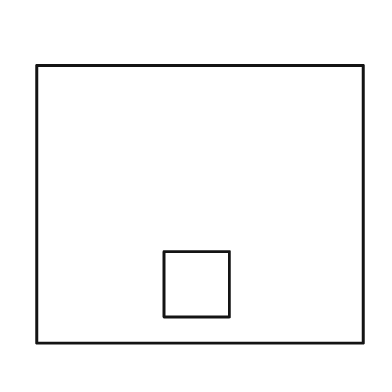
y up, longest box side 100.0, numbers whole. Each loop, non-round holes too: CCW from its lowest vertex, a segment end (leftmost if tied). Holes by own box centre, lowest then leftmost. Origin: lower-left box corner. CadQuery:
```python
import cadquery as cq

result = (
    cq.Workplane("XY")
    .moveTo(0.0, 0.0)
    .lineTo(100.0, 0.0)
    .lineTo(100.0, 85.0)
    .lineTo(0.0, 85.0)
    .close()
    .moveTo(39.0, 8.0)
    .lineTo(59.0, 8.0)
    .lineTo(59.0, 28.0)
    .lineTo(39.0, 28.0)
    .close()
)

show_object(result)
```